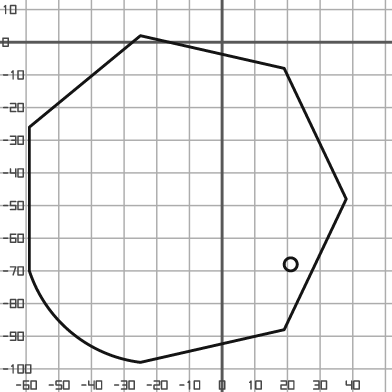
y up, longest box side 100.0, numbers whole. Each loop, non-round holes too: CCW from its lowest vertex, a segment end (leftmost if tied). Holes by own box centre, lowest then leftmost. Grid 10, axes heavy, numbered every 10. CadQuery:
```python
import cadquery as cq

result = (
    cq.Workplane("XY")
    .moveTo(-25.0, -98.0)
    .lineTo(19.0, -88.0)
    .lineTo(38.0, -48.0)
    .lineTo(19.0, -8.0)
    .lineTo(-25.0, 2.0)
    .lineTo(-59.0, -26.0)
    .lineTo(-59.0, -70.0)
    .threePointArc((-46.0, -89.0), (-25.0, -98.0))
    .close()
    .moveTo(21.0, -68.0)
    .circle(2.0)
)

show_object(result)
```